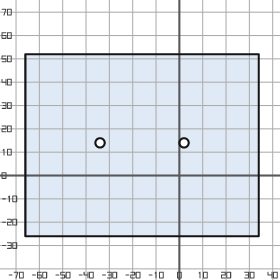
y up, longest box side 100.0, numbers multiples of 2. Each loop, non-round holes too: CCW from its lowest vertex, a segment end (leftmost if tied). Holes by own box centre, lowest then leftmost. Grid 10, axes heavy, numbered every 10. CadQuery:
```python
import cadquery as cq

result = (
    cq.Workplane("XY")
    .moveTo(-66.0, -26.0)
    .lineTo(34.0, -26.0)
    .lineTo(34.0, 52.0)
    .lineTo(-66.0, 52.0)
    .close()
    .moveTo(-34.0, 14.0)
    .circle(2.0)
    .moveTo(2.0, 14.0)
    .circle(2.0)
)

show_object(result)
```